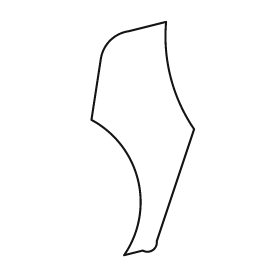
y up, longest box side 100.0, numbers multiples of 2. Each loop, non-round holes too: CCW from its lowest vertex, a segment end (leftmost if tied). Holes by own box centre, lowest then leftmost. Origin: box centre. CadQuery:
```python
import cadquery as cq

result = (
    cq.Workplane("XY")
    .moveTo(-8.0, -50.0)
    .lineTo(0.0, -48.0)
    .threePointArc((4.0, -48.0), (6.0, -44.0))
    .lineTo(22.0, 4.0)
    .threePointArc((12.0, 26.0), (10.0, 50.0))
    .lineTo(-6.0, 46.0)
    .threePointArc((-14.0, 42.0), (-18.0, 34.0))
    .lineTo(-22.0, 8.0)
    .threePointArc((-2.0, -18.0), (-8.0, -50.0))
    .close()
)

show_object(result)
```